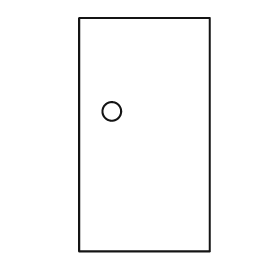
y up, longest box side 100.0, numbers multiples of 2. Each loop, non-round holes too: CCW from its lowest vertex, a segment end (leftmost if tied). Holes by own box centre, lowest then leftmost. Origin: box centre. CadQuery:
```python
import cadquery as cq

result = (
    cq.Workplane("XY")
    .moveTo(-28.0, -50.0)
    .lineTo(28.0, -50.0)
    .lineTo(28.0, 50.0)
    .lineTo(-28.0, 50.0)
    .close()
    .moveTo(-14.0, 10.0)
    .circle(4.0)
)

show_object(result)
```